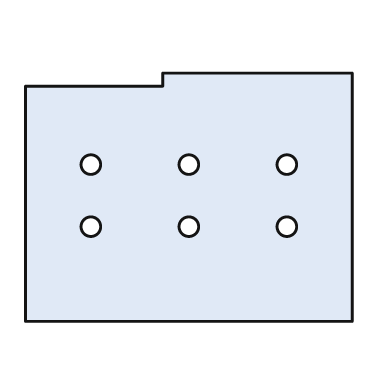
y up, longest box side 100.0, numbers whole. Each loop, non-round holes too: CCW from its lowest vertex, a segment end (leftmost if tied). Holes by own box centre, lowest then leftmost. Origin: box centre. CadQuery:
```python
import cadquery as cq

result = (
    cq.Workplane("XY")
    .moveTo(-50.0, -38.0)
    .lineTo(50.0, -38.0)
    .lineTo(50.0, 38.0)
    .lineTo(-8.0, 38.0)
    .lineTo(-8.0, 34.0)
    .lineTo(-50.0, 34.0)
    .close()
    .moveTo(-30.0, -9.0)
    .circle(3.0)
    .moveTo(0.0, -9.0)
    .circle(3.0)
    .moveTo(30.0, -9.0)
    .circle(3.0)
    .moveTo(-30.0, 10.0)
    .circle(3.0)
    .moveTo(0.0, 10.0)
    .circle(3.0)
    .moveTo(30.0, 10.0)
    .circle(3.0)
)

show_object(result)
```